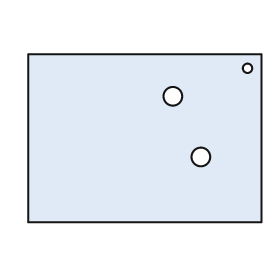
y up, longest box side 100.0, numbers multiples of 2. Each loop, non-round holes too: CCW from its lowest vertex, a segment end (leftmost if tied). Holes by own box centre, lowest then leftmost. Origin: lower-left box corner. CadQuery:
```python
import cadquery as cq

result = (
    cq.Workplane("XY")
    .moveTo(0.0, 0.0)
    .lineTo(100.0, 0.0)
    .lineTo(100.0, 72.0)
    .lineTo(0.0, 72.0)
    .close()
    .moveTo(74.0, 28.0)
    .circle(4.0)
    .moveTo(62.0, 54.0)
    .circle(4.0)
    .moveTo(94.0, 66.0)
    .circle(2.0)
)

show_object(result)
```